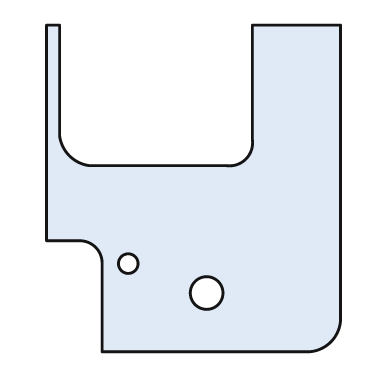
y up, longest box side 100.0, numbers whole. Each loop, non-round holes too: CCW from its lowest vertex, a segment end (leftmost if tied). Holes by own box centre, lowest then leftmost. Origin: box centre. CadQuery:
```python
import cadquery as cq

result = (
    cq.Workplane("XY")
    .moveTo(-28.0, -50.0)
    .lineTo(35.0, -50.0)
    .threePointArc((42.0, -47.0), (45.0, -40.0))
    .lineTo(45.0, 50.0)
    .lineTo(18.0, 50.0)
    .lineTo(18.0, 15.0)
    .threePointArc((16.0, 9.0), (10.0, 7.0))
    .lineTo(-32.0, 7.0)
    .threePointArc((-38.0, 10.0), (-41.0, 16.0))
    .lineTo(-41.0, 50.0)
    .lineTo(-45.0, 50.0)
    .lineTo(-45.0, -16.0)
    .lineTo(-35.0, -16.0)
    .threePointArc((-30.0, -18.0), (-28.0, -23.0))
    .close()
    .moveTo(4.0, -32.0)
    .circle(5.0)
    .moveTo(-20.0, -23.0)
    .circle(3.0)
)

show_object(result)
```